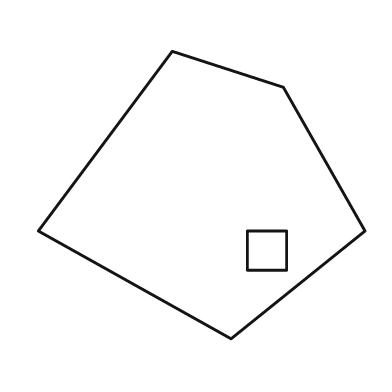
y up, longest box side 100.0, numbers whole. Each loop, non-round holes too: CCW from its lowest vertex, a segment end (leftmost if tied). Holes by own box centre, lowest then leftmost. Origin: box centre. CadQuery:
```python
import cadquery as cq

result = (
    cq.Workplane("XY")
    .moveTo(9.0, -44.0)
    .lineTo(50.0, -11.0)
    .lineTo(25.0, 33.0)
    .lineTo(-9.0, 44.0)
    .lineTo(-50.0, -11.0)
    .close()
    .moveTo(14.0, -23.0)
    .lineTo(26.0, -23.0)
    .lineTo(26.0, -11.0)
    .lineTo(14.0, -11.0)
    .close()
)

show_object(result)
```